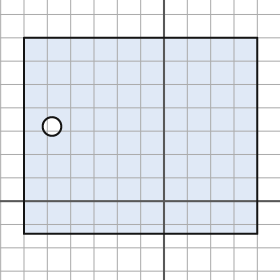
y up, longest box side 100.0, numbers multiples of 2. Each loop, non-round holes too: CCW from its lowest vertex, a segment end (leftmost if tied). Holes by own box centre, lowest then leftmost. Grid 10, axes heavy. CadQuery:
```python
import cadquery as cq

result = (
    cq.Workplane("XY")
    .moveTo(-60.0, -14.0)
    .lineTo(40.0, -14.0)
    .lineTo(40.0, 70.0)
    .lineTo(-60.0, 70.0)
    .close()
    .moveTo(-48.0, 32.0)
    .circle(4.0)
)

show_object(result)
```